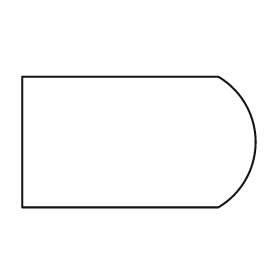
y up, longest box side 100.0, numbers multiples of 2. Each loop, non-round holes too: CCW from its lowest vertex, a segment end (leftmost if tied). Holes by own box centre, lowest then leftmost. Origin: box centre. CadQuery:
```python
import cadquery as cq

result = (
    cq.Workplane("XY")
    .moveTo(-50.0, -28.0)
    .lineTo(34.0, -28.0)
    .threePointArc((50.0, 0.0), (34.0, 28.0))
    .lineTo(-50.0, 28.0)
    .close()
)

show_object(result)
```